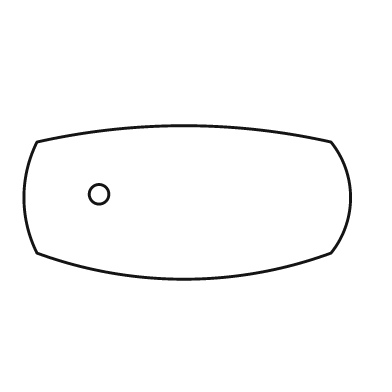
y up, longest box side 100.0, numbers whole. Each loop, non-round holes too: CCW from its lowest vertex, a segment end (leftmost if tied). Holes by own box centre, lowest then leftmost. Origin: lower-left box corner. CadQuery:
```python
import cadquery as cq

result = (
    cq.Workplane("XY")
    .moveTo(4.0, 8.0)
    .threePointArc((49.0, 0.0), (94.0, 8.0))
    .threePointArc((100.0, 25.0), (94.0, 42.0))
    .threePointArc((49.0, 47.0), (4.0, 42.0))
    .threePointArc((0.0, 25.0), (4.0, 8.0))
    .close()
    .moveTo(23.0, 26.0)
    .circle(3.0)
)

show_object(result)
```